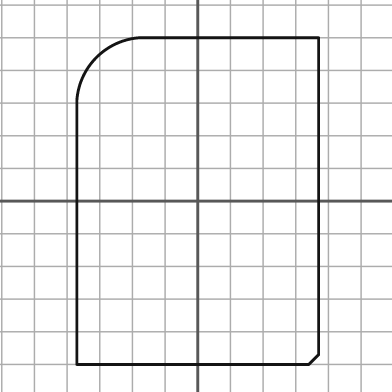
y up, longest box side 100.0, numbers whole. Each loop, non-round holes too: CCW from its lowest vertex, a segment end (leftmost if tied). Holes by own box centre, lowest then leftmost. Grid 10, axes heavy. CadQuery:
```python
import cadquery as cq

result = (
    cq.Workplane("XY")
    .moveTo(-37.0, -50.0)
    .lineTo(34.0, -50.0)
    .lineTo(37.0, -47.0)
    .lineTo(37.0, 50.0)
    .lineTo(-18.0, 50.0)
    .threePointArc((-31.0, 44.0), (-37.0, 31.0))
    .close()
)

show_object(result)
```